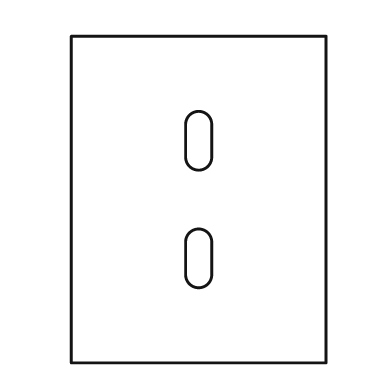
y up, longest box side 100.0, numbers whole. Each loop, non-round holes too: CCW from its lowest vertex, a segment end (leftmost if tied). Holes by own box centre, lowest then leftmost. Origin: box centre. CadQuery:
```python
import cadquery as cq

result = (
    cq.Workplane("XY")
    .moveTo(-39.0, -50.0)
    .lineTo(39.0, -50.0)
    .lineTo(39.0, 50.0)
    .lineTo(-39.0, 50.0)
    .close()
    .moveTo(-4.0, -23.0)
    .threePointArc((0.0, -27.0), (4.0, -23.0))
    .lineTo(4.0, -13.0)
    .threePointArc((0.0, -9.0), (-4.0, -13.0))
    .close()
    .moveTo(-4.0, 13.0)
    .threePointArc((0.0, 9.0), (4.0, 13.0))
    .lineTo(4.0, 23.0)
    .threePointArc((0.0, 27.0), (-4.0, 23.0))
    .close()
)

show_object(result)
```